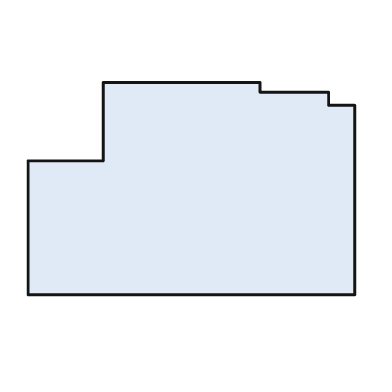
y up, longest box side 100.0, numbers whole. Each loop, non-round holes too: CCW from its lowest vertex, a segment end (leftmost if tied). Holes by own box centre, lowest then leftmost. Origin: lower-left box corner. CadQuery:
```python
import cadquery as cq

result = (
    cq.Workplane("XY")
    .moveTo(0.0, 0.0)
    .lineTo(100.0, 0.0)
    .lineTo(100.0, 58.0)
    .lineTo(92.0, 58.0)
    .lineTo(92.0, 62.0)
    .lineTo(71.0, 62.0)
    .lineTo(71.0, 65.0)
    .lineTo(23.0, 65.0)
    .lineTo(23.0, 41.0)
    .lineTo(0.0, 41.0)
    .close()
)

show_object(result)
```